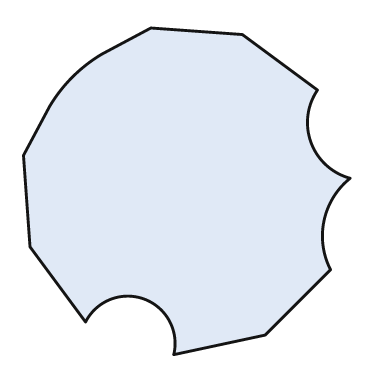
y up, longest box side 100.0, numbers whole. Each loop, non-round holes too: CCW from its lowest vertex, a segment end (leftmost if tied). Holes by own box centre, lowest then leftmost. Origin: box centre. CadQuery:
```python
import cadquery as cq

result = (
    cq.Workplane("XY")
    .moveTo(-4.0, -50.0)
    .lineTo(24.0, -44.0)
    .lineTo(44.0, -24.0)
    .threePointArc((42.0, -9.0), (50.0, 4.0))
    .threePointArc((38.0, 15.0), (40.0, 31.0))
    .lineTo(17.0, 48.0)
    .lineTo(-11.0, 50.0)
    .lineTo(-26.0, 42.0)
    .threePointArc((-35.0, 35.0), (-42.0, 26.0))
    .lineTo(-50.0, 11.0)
    .lineTo(-48.0, -17.0)
    .lineTo(-31.0, -40.0)
    .threePointArc((-13.0, -33.0), (-4.0, -50.0))
    .close()
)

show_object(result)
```